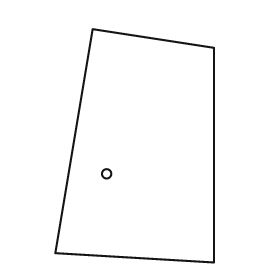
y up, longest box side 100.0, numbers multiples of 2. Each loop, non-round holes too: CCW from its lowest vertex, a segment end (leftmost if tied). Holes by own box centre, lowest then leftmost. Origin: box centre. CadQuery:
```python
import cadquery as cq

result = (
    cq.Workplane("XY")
    .moveTo(34.0, -50.0)
    .lineTo(34.0, 42.0)
    .lineTo(-18.0, 50.0)
    .lineTo(-34.0, -46.0)
    .close()
    .moveTo(-12.0, -12.0)
    .circle(2.0)
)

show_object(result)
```